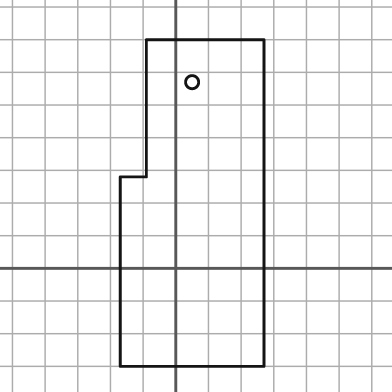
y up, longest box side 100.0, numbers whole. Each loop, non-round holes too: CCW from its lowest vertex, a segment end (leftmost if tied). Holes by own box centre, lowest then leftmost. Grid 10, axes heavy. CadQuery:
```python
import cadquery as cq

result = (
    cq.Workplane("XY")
    .moveTo(-17.0, -30.0)
    .lineTo(27.0, -30.0)
    .lineTo(27.0, 70.0)
    .lineTo(-9.0, 70.0)
    .lineTo(-9.0, 28.0)
    .lineTo(-17.0, 28.0)
    .close()
    .moveTo(5.0, 57.0)
    .circle(2.0)
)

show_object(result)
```